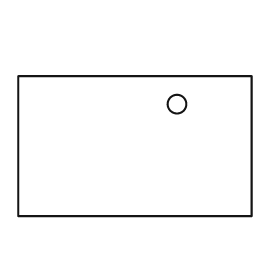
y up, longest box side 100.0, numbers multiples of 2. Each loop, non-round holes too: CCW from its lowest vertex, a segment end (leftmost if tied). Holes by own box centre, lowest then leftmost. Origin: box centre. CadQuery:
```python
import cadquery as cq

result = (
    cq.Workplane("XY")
    .moveTo(-50.0, -30.0)
    .lineTo(50.0, -30.0)
    .lineTo(50.0, 30.0)
    .lineTo(-50.0, 30.0)
    .close()
    .moveTo(18.0, 18.0)
    .circle(4.0)
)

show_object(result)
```